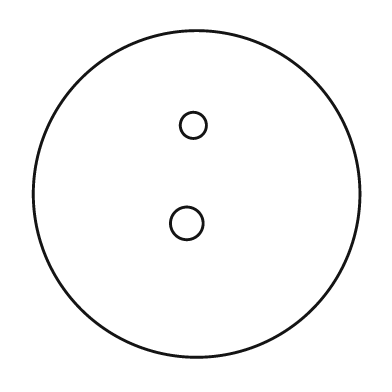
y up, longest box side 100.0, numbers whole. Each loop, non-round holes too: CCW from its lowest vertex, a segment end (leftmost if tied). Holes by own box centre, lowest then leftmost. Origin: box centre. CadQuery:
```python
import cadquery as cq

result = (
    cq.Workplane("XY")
    .moveTo(0.0, 0.0)
    .circle(50.0)
    .moveTo(-3.0, -9.0)
    .circle(5.0)
    .moveTo(-1.0, 21.0)
    .circle(4.0)
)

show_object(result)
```